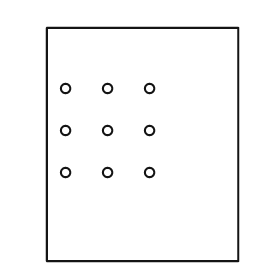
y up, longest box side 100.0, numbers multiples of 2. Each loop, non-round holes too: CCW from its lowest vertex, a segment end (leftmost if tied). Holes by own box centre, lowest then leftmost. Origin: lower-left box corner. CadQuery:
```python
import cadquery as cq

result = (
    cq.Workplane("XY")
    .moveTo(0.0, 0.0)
    .lineTo(82.0, 0.0)
    .lineTo(82.0, 100.0)
    .lineTo(0.0, 100.0)
    .close()
    .moveTo(8.0, 38.0)
    .circle(2.0)
    .moveTo(26.0, 38.0)
    .circle(2.0)
    .moveTo(44.0, 38.0)
    .circle(2.0)
    .moveTo(8.0, 56.0)
    .circle(2.0)
    .moveTo(26.0, 56.0)
    .circle(2.0)
    .moveTo(44.0, 56.0)
    .circle(2.0)
    .moveTo(8.0, 74.0)
    .circle(2.0)
    .moveTo(26.0, 74.0)
    .circle(2.0)
    .moveTo(44.0, 74.0)
    .circle(2.0)
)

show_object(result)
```